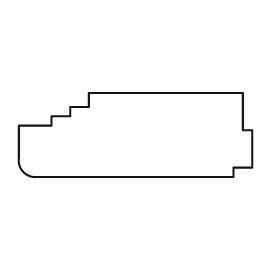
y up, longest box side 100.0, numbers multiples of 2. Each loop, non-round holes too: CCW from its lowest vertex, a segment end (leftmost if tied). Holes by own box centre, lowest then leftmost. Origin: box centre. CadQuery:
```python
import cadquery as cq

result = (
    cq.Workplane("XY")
    .moveTo(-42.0, -18.0)
    .lineTo(42.0, -18.0)
    .lineTo(42.0, -14.0)
    .lineTo(50.0, -14.0)
    .lineTo(50.0, 2.0)
    .lineTo(46.0, 2.0)
    .lineTo(46.0, 18.0)
    .lineTo(-20.0, 18.0)
    .lineTo(-20.0, 12.0)
    .lineTo(-28.0, 12.0)
    .lineTo(-28.0, 8.0)
    .lineTo(-36.0, 8.0)
    .lineTo(-36.0, 4.0)
    .lineTo(-50.0, 4.0)
    .lineTo(-50.0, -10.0)
    .threePointArc((-48.0, -16.0), (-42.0, -18.0))
    .close()
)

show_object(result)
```